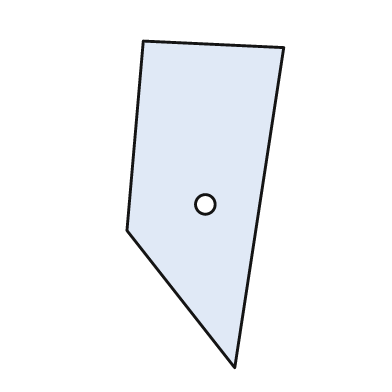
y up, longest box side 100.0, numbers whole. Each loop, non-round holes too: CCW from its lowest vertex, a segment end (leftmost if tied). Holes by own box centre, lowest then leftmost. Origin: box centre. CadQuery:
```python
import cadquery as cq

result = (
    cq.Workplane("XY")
    .moveTo(9.0, -50.0)
    .lineTo(24.0, 48.0)
    .lineTo(-19.0, 50.0)
    .lineTo(-24.0, -8.0)
    .close()
    .moveTo(0.0, 0.0)
    .circle(3.0)
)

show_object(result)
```